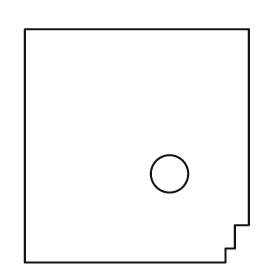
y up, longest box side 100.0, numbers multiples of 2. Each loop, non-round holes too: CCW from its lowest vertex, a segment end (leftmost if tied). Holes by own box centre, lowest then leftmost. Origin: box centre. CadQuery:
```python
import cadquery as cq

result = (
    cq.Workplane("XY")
    .moveTo(-48.0, -50.0)
    .lineTo(38.0, -50.0)
    .lineTo(38.0, -44.0)
    .lineTo(42.0, -44.0)
    .lineTo(42.0, -34.0)
    .lineTo(48.0, -34.0)
    .lineTo(48.0, 50.0)
    .lineTo(-48.0, 50.0)
    .close()
    .moveTo(14.0, -12.0)
    .circle(8.0)
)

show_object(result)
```